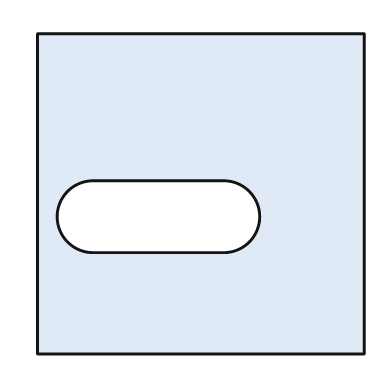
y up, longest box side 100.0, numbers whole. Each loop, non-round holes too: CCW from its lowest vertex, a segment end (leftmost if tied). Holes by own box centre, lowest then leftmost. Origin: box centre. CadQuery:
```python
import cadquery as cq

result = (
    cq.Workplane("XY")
    .moveTo(-50.0, -49.0)
    .lineTo(50.0, -49.0)
    .lineTo(50.0, 49.0)
    .lineTo(-50.0, 49.0)
    .close()
    .moveTo(-33.0, -18.0)
    .lineTo(7.0, -18.0)
    .threePointArc((18.0, -7.0), (7.0, 4.0))
    .lineTo(-33.0, 4.0)
    .threePointArc((-44.0, -7.0), (-33.0, -18.0))
    .close()
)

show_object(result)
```